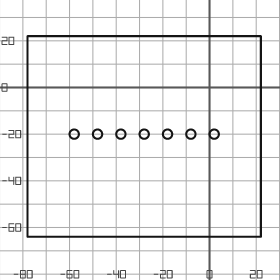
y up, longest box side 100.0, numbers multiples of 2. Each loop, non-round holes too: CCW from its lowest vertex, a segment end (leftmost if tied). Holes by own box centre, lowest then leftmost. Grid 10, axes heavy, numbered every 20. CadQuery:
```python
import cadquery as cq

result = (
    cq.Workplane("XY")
    .moveTo(-78.0, -64.0)
    .lineTo(22.0, -64.0)
    .lineTo(22.0, 22.0)
    .lineTo(-78.0, 22.0)
    .close()
    .moveTo(-58.0, -20.0)
    .circle(2.0)
    .moveTo(-48.0, -20.0)
    .circle(2.0)
    .moveTo(-38.0, -20.0)
    .circle(2.0)
    .moveTo(-28.0, -20.0)
    .circle(2.0)
    .moveTo(-18.0, -20.0)
    .circle(2.0)
    .moveTo(-8.0, -20.0)
    .circle(2.0)
    .moveTo(2.0, -20.0)
    .circle(2.0)
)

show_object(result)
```